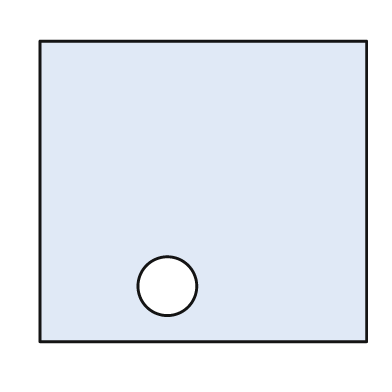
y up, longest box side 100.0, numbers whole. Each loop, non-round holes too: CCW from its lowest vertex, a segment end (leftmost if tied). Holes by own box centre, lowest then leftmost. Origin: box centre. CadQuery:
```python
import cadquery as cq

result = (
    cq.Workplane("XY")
    .moveTo(-50.0, -46.0)
    .lineTo(50.0, -46.0)
    .lineTo(50.0, 46.0)
    .lineTo(-50.0, 46.0)
    .close()
    .moveTo(-11.0, -29.0)
    .circle(9.0)
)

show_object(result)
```